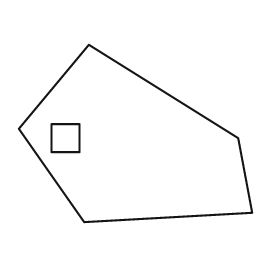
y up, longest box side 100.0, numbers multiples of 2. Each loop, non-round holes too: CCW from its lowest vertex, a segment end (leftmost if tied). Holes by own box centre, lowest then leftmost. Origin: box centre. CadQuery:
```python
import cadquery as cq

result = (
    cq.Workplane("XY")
    .moveTo(-22.0, -38.0)
    .lineTo(50.0, -34.0)
    .lineTo(44.0, -2.0)
    .lineTo(-20.0, 38.0)
    .lineTo(-50.0, 2.0)
    .close()
    .moveTo(-36.0, -8.0)
    .lineTo(-24.0, -8.0)
    .lineTo(-24.0, 4.0)
    .lineTo(-36.0, 4.0)
    .close()
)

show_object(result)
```